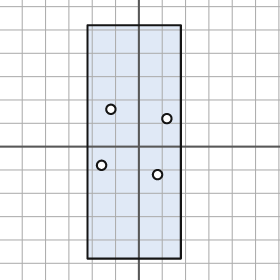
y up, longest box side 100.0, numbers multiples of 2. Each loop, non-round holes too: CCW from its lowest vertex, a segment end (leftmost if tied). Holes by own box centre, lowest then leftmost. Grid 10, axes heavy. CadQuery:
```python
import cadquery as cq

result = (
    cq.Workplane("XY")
    .moveTo(-22.0, -48.0)
    .lineTo(18.0, -48.0)
    .lineTo(18.0, 52.0)
    .lineTo(-22.0, 52.0)
    .close()
    .moveTo(8.0, -12.0)
    .circle(2.0)
    .moveTo(-16.0, -8.0)
    .circle(2.0)
    .moveTo(12.0, 12.0)
    .circle(2.0)
    .moveTo(-12.0, 16.0)
    .circle(2.0)
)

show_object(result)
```